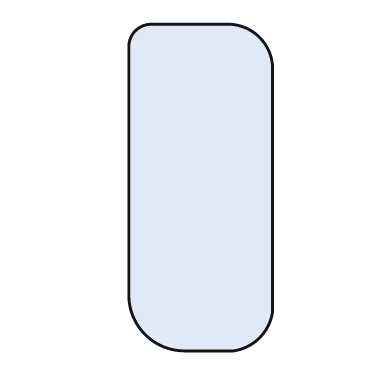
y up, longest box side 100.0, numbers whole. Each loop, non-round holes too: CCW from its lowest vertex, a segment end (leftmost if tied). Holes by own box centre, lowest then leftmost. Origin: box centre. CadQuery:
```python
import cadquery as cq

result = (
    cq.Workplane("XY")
    .moveTo(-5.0, -50.0)
    .lineTo(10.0, -50.0)
    .threePointArc((18.0, -46.0), (22.0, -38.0))
    .lineTo(22.0, 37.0)
    .threePointArc((18.0, 46.0), (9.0, 50.0))
    .lineTo(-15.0, 50.0)
    .threePointArc((-20.0, 48.0), (-22.0, 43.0))
    .lineTo(-22.0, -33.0)
    .threePointArc((-17.0, -45.0), (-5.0, -50.0))
    .close()
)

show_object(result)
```